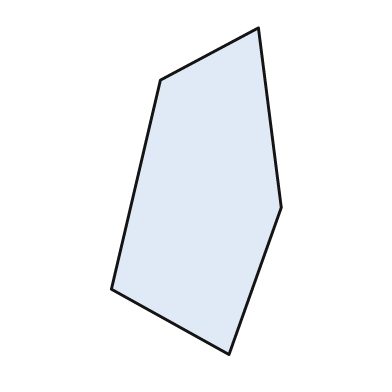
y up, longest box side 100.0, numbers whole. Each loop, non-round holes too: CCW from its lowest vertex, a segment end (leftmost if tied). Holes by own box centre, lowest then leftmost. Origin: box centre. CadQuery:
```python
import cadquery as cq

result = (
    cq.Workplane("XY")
    .moveTo(10.0, -50.0)
    .lineTo(26.0, -5.0)
    .lineTo(19.0, 50.0)
    .lineTo(-11.0, 34.0)
    .lineTo(-26.0, -30.0)
    .close()
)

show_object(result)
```